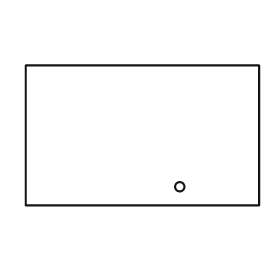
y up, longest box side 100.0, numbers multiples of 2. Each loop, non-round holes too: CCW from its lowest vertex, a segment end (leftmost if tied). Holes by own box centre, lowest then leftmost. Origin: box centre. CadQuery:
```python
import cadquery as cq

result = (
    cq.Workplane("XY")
    .moveTo(-50.0, -30.0)
    .lineTo(50.0, -30.0)
    .lineTo(50.0, 30.0)
    .lineTo(-50.0, 30.0)
    .close()
    .moveTo(16.0, -22.0)
    .circle(2.0)
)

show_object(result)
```